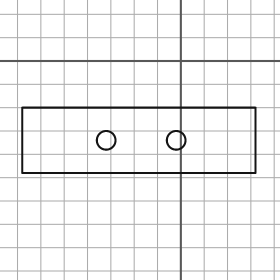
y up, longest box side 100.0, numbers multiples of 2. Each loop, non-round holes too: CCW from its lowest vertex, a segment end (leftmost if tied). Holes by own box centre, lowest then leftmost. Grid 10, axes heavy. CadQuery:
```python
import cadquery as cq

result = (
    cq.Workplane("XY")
    .moveTo(-68.0, -48.0)
    .lineTo(32.0, -48.0)
    .lineTo(32.0, -20.0)
    .lineTo(-68.0, -20.0)
    .close()
    .moveTo(-32.0, -34.0)
    .circle(4.0)
    .moveTo(-2.0, -34.0)
    .circle(4.0)
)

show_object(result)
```